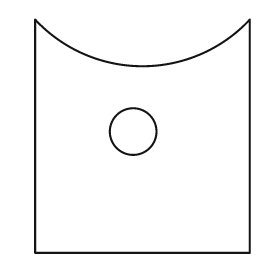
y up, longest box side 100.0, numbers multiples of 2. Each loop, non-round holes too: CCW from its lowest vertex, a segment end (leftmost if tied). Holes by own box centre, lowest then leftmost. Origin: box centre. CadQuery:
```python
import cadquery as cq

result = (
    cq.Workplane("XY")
    .moveTo(-46.0, -50.0)
    .lineTo(46.0, -50.0)
    .lineTo(46.0, 50.0)
    .threePointArc((0.0, 30.0), (-46.0, 50.0))
    .close()
    .moveTo(-4.0, 2.0)
    .circle(10.0)
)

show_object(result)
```